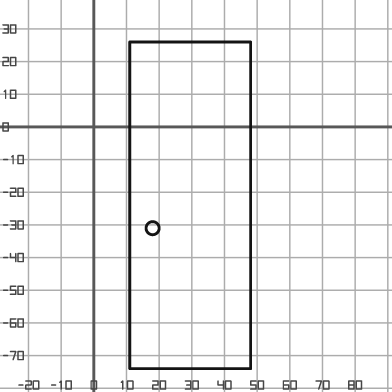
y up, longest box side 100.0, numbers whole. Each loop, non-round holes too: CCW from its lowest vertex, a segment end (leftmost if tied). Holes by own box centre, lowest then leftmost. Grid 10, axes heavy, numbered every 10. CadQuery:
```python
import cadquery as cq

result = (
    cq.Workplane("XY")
    .moveTo(11.0, -74.0)
    .lineTo(48.0, -74.0)
    .lineTo(48.0, 26.0)
    .lineTo(11.0, 26.0)
    .close()
    .moveTo(18.0, -31.0)
    .circle(2.0)
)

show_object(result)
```